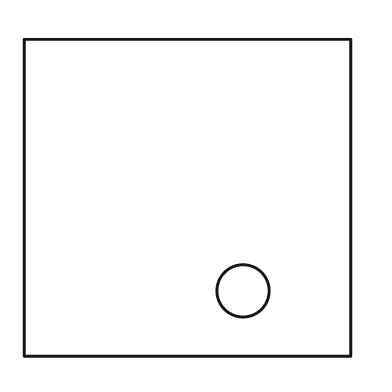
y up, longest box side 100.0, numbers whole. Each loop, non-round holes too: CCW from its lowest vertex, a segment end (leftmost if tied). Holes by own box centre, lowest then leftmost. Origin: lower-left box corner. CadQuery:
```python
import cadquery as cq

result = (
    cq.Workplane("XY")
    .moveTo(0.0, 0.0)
    .lineTo(100.0, 0.0)
    .lineTo(100.0, 97.0)
    .lineTo(0.0, 97.0)
    .close()
    .moveTo(67.0, 20.0)
    .circle(8.0)
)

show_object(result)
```